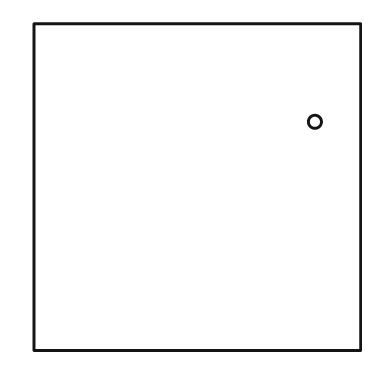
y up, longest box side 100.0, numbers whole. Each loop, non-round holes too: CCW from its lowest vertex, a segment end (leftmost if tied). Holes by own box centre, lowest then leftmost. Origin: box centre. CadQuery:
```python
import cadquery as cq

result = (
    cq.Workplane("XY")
    .moveTo(-50.0, -50.0)
    .lineTo(50.0, -50.0)
    .lineTo(50.0, 50.0)
    .lineTo(-50.0, 50.0)
    .close()
    .moveTo(36.0, 20.0)
    .circle(2.0)
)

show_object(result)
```